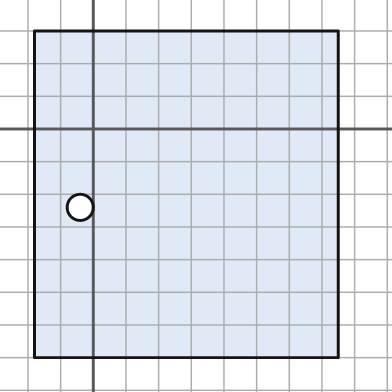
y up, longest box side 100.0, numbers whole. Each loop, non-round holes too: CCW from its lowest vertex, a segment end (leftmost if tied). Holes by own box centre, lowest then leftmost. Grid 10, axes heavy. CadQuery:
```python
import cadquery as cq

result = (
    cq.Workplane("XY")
    .moveTo(-18.0, -70.0)
    .lineTo(75.0, -70.0)
    .lineTo(75.0, 30.0)
    .lineTo(-18.0, 30.0)
    .close()
    .moveTo(-4.0, -24.0)
    .circle(4.0)
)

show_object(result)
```